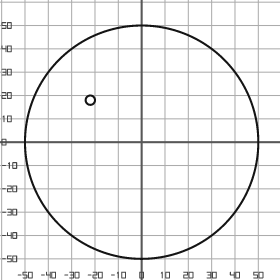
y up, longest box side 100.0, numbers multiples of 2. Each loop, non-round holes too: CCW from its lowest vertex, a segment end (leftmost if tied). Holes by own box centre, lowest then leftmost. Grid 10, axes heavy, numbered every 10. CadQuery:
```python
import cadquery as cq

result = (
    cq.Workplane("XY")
    .moveTo(0.0, 0.0)
    .circle(50.0)
    .moveTo(-22.0, 18.0)
    .circle(2.0)
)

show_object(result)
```